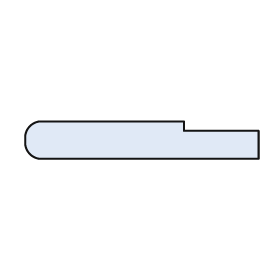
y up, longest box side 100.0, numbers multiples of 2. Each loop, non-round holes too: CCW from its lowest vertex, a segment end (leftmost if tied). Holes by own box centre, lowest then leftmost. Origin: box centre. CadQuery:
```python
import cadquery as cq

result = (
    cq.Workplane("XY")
    .moveTo(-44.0, -8.0)
    .lineTo(50.0, -8.0)
    .lineTo(50.0, 4.0)
    .lineTo(18.0, 4.0)
    .lineTo(18.0, 8.0)
    .lineTo(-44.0, 8.0)
    .threePointArc((-48.0, 6.0), (-50.0, 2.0))
    .lineTo(-50.0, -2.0)
    .threePointArc((-48.0, -6.0), (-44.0, -8.0))
    .close()
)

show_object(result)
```